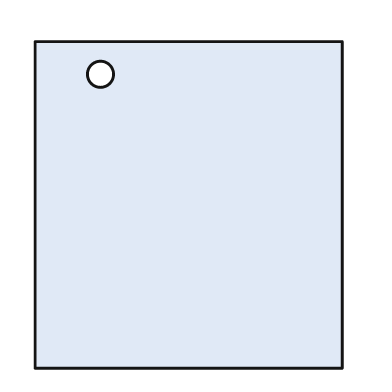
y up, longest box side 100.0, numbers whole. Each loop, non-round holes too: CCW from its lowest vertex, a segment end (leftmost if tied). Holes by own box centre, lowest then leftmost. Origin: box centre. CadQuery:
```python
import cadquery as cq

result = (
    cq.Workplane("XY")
    .moveTo(-47.0, -50.0)
    .lineTo(47.0, -50.0)
    .lineTo(47.0, 50.0)
    .lineTo(-47.0, 50.0)
    .close()
    .moveTo(-27.0, 40.0)
    .circle(4.0)
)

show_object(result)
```